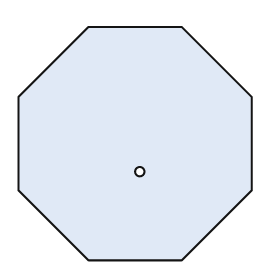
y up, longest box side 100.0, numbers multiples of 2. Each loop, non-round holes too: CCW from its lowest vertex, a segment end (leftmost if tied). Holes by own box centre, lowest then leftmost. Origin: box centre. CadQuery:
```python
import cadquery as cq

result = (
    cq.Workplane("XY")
    .moveTo(-20.0, -50.0)
    .lineTo(20.0, -50.0)
    .lineTo(50.0, -20.0)
    .lineTo(50.0, 20.0)
    .lineTo(20.0, 50.0)
    .lineTo(-20.0, 50.0)
    .lineTo(-50.0, 20.0)
    .lineTo(-50.0, -20.0)
    .close()
    .moveTo(2.0, -12.0)
    .circle(2.0)
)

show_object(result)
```